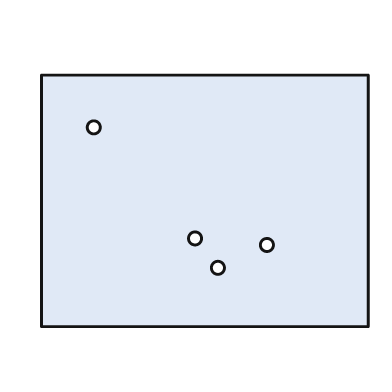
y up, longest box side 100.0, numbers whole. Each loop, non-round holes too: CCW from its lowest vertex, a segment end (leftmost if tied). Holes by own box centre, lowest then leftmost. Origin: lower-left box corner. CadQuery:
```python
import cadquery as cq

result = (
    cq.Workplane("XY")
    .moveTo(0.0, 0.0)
    .lineTo(100.0, 0.0)
    .lineTo(100.0, 77.0)
    .lineTo(0.0, 77.0)
    .close()
    .moveTo(54.0, 18.0)
    .circle(2.0)
    .moveTo(69.0, 25.0)
    .circle(2.0)
    .moveTo(47.0, 27.0)
    .circle(2.0)
    .moveTo(16.0, 61.0)
    .circle(2.0)
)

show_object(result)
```